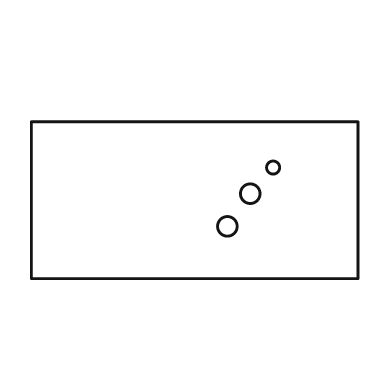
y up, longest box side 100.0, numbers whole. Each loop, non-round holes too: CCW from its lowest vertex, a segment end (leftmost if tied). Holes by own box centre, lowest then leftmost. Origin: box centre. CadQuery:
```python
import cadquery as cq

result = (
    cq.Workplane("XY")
    .moveTo(-50.0, -24.0)
    .lineTo(50.0, -24.0)
    .lineTo(50.0, 24.0)
    .lineTo(-50.0, 24.0)
    .close()
    .moveTo(10.0, -8.0)
    .circle(3.0)
    .moveTo(17.0, 2.0)
    .circle(3.0)
    .moveTo(24.0, 10.0)
    .circle(2.0)
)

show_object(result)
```